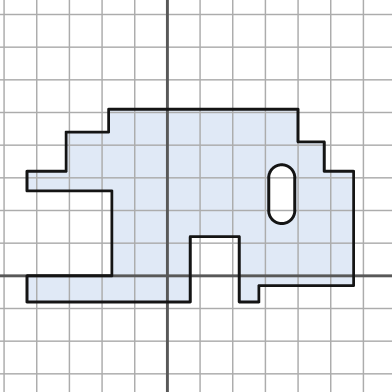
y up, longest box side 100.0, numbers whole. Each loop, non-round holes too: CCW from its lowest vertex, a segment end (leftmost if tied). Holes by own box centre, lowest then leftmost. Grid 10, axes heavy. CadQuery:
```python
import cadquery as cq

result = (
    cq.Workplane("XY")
    .moveTo(-43.0, -8.0)
    .lineTo(7.0, -8.0)
    .lineTo(7.0, 12.0)
    .lineTo(22.0, 12.0)
    .lineTo(22.0, -8.0)
    .lineTo(28.0, -8.0)
    .lineTo(28.0, -3.0)
    .lineTo(57.0, -3.0)
    .lineTo(57.0, 32.0)
    .lineTo(48.0, 32.0)
    .lineTo(48.0, 41.0)
    .lineTo(40.0, 41.0)
    .lineTo(40.0, 51.0)
    .lineTo(-18.0, 51.0)
    .lineTo(-18.0, 44.0)
    .lineTo(-31.0, 44.0)
    .lineTo(-31.0, 32.0)
    .lineTo(-43.0, 32.0)
    .lineTo(-43.0, 26.0)
    .lineTo(-17.0, 26.0)
    .lineTo(-17.0, 0.0)
    .lineTo(-43.0, 0.0)
    .close()
    .moveTo(31.0, 20.0)
    .threePointArc((35.0, 16.0), (39.0, 20.0))
    .lineTo(39.0, 30.0)
    .threePointArc((35.0, 34.0), (31.0, 30.0))
    .close()
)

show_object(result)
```